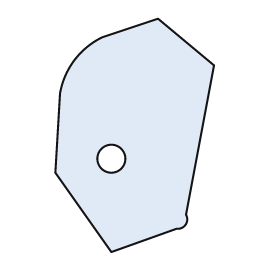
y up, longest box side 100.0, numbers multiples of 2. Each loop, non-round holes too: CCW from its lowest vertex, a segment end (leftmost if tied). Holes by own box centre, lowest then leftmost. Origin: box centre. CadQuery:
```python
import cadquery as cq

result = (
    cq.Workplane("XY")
    .moveTo(-10.0, -50.0)
    .lineTo(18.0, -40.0)
    .threePointArc((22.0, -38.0), (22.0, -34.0))
    .lineTo(34.0, 30.0)
    .lineTo(10.0, 50.0)
    .lineTo(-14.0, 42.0)
    .threePointArc((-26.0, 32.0), (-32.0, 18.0))
    .lineTo(-34.0, -16.0)
    .close()
    .moveTo(-10.0, -10.0)
    .circle(6.0)
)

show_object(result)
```